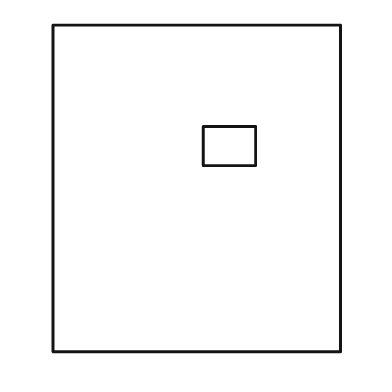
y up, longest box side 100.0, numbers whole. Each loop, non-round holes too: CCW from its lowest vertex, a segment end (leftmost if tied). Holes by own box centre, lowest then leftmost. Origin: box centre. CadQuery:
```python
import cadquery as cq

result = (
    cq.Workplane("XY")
    .moveTo(-44.0, -50.0)
    .lineTo(44.0, -50.0)
    .lineTo(44.0, 50.0)
    .lineTo(-44.0, 50.0)
    .close()
    .moveTo(2.0, 7.0)
    .lineTo(18.0, 7.0)
    .lineTo(18.0, 19.0)
    .lineTo(2.0, 19.0)
    .close()
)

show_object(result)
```